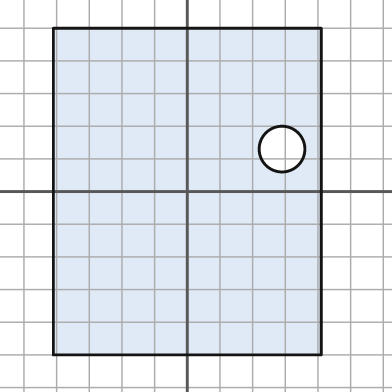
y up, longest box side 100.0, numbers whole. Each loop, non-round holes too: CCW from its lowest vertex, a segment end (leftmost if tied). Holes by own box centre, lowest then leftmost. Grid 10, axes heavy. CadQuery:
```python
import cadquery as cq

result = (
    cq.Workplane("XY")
    .moveTo(-41.0, -50.0)
    .lineTo(41.0, -50.0)
    .lineTo(41.0, 50.0)
    .lineTo(-41.0, 50.0)
    .close()
    .moveTo(29.0, 13.0)
    .circle(7.0)
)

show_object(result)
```